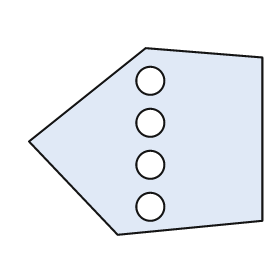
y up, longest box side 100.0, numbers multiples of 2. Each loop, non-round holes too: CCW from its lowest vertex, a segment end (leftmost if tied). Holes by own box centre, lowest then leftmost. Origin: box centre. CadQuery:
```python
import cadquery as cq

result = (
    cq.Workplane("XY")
    .moveTo(-12.0, -40.0)
    .lineTo(50.0, -34.0)
    .lineTo(50.0, 36.0)
    .lineTo(0.0, 40.0)
    .lineTo(-50.0, 0.0)
    .close()
    .moveTo(2.0, -28.0)
    .circle(6.0)
    .moveTo(2.0, -10.0)
    .circle(6.0)
    .moveTo(2.0, 8.0)
    .circle(6.0)
    .moveTo(2.0, 26.0)
    .circle(6.0)
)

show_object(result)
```